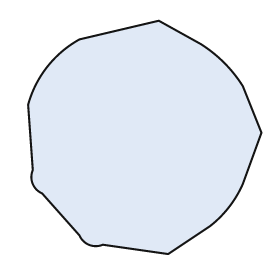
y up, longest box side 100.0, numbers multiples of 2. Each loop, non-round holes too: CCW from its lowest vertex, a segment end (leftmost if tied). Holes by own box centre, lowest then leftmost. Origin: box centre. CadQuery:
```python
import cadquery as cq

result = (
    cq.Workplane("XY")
    .moveTo(10.0, -50.0)
    .lineTo(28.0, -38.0)
    .threePointArc((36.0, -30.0), (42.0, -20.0))
    .lineTo(50.0, 2.0)
    .lineTo(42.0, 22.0)
    .threePointArc((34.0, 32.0), (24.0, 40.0))
    .lineTo(6.0, 50.0)
    .lineTo(-28.0, 42.0)
    .threePointArc((-42.0, 30.0), (-50.0, 14.0))
    .lineTo(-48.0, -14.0)
    .threePointArc((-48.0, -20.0), (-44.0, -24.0))
    .lineTo(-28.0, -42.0)
    .threePointArc((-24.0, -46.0), (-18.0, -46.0))
    .close()
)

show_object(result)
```